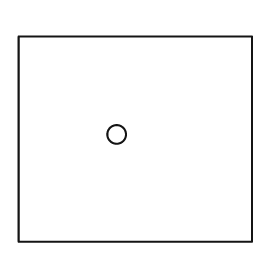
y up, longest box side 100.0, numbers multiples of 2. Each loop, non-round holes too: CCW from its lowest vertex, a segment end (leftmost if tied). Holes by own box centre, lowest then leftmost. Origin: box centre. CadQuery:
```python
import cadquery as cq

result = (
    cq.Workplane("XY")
    .moveTo(-50.0, -44.0)
    .lineTo(50.0, -44.0)
    .lineTo(50.0, 44.0)
    .lineTo(-50.0, 44.0)
    .close()
    .moveTo(-8.0, 2.0)
    .circle(4.0)
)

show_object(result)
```